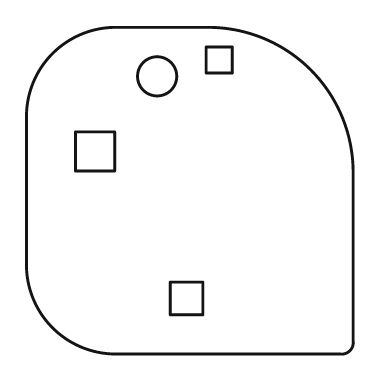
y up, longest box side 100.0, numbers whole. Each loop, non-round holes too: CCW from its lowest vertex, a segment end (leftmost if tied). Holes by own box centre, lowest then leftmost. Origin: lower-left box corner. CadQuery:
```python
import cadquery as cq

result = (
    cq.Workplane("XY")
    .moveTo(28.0, 0.0)
    .lineTo(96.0, 0.0)
    .threePointArc((99.0, 1.0), (100.0, 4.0))
    .lineTo(100.0, 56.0)
    .threePointArc((87.0, 87.0), (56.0, 100.0))
    .lineTo(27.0, 100.0)
    .threePointArc((8.0, 92.0), (0.0, 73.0))
    .lineTo(0.0, 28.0)
    .threePointArc((8.0, 8.0), (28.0, 0.0))
    .close()
    .moveTo(44.0, 12.0)
    .lineTo(54.0, 12.0)
    .lineTo(54.0, 22.0)
    .lineTo(44.0, 22.0)
    .close()
    .moveTo(15.0, 56.0)
    .lineTo(27.0, 56.0)
    .lineTo(27.0, 68.0)
    .lineTo(15.0, 68.0)
    .close()
    .moveTo(40.0, 85.0)
    .circle(6.0)
    .moveTo(55.0, 86.0)
    .lineTo(63.0, 86.0)
    .lineTo(63.0, 94.0)
    .lineTo(55.0, 94.0)
    .close()
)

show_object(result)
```